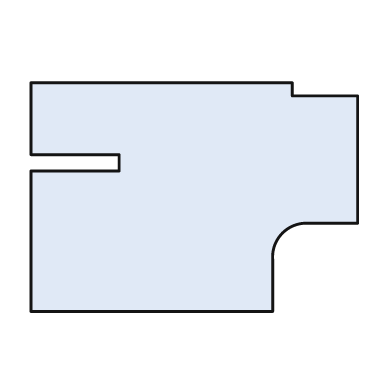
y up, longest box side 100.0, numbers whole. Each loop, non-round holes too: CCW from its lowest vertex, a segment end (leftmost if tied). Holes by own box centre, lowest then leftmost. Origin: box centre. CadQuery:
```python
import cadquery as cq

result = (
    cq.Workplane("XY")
    .moveTo(-50.0, -35.0)
    .lineTo(24.0, -35.0)
    .lineTo(24.0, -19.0)
    .threePointArc((27.0, -11.0), (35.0, -8.0))
    .lineTo(50.0, -8.0)
    .lineTo(50.0, 31.0)
    .lineTo(30.0, 31.0)
    .lineTo(30.0, 35.0)
    .lineTo(-50.0, 35.0)
    .lineTo(-50.0, 13.0)
    .lineTo(-23.0, 13.0)
    .lineTo(-23.0, 8.0)
    .lineTo(-50.0, 8.0)
    .close()
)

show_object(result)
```